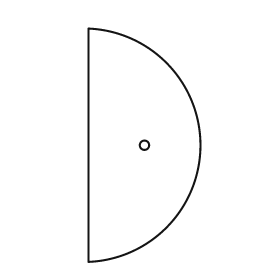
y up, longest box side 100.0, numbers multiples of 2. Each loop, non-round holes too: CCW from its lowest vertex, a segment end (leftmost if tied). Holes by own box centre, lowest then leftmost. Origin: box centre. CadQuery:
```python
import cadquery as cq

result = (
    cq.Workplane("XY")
    .moveTo(-24.0, -50.0)
    .threePointArc((24.0, 0.0), (-24.0, 50.0))
    .close()
    .moveTo(0.0, 0.0)
    .circle(2.0)
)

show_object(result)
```